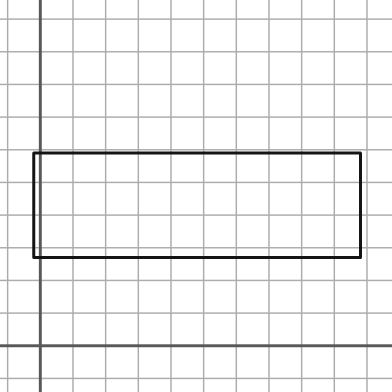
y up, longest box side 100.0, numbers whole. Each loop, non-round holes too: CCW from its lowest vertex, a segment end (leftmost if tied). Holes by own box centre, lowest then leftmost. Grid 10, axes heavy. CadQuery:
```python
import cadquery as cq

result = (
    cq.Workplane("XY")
    .moveTo(-2.0, 27.0)
    .lineTo(98.0, 27.0)
    .lineTo(98.0, 59.0)
    .lineTo(-2.0, 59.0)
    .close()
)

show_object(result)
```